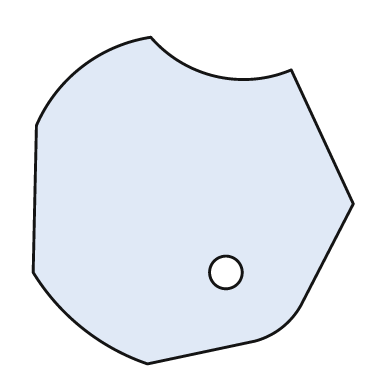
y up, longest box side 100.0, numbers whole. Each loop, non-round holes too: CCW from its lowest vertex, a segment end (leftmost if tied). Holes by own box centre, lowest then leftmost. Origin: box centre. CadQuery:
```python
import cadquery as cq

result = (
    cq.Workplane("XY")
    .moveTo(-14.0, -50.0)
    .lineTo(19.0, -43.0)
    .threePointArc((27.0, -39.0), (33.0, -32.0))
    .lineTo(49.0, -1.0)
    .lineTo(30.0, 40.0)
    .threePointArc((7.0, 38.0), (-13.0, 50.0))
    .threePointArc((-34.0, 41.0), (-48.0, 23.0))
    .lineTo(-49.0, -22.0)
    .threePointArc((-34.0, -39.0), (-14.0, -50.0))
    .close()
    .moveTo(10.0, -22.0)
    .circle(5.0)
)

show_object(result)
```